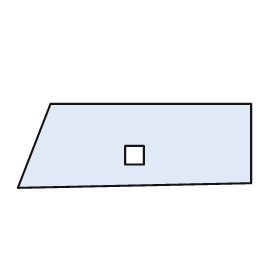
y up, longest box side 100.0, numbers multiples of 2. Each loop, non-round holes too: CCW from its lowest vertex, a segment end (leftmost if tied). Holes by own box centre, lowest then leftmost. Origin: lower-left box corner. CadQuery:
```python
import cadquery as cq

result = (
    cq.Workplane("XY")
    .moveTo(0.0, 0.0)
    .lineTo(100.0, 2.0)
    .lineTo(100.0, 36.0)
    .lineTo(14.0, 36.0)
    .close()
    .moveTo(46.0, 10.0)
    .lineTo(54.0, 10.0)
    .lineTo(54.0, 18.0)
    .lineTo(46.0, 18.0)
    .close()
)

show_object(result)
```